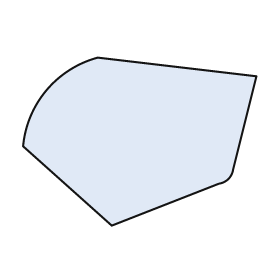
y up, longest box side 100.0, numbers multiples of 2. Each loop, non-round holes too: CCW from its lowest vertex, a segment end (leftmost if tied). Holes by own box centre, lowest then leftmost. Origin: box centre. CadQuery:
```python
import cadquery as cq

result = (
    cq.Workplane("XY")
    .moveTo(-12.0, -36.0)
    .lineTo(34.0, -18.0)
    .threePointArc((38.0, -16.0), (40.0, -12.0))
    .lineTo(50.0, 28.0)
    .lineTo(-18.0, 36.0)
    .threePointArc((-40.0, 22.0), (-50.0, -2.0))
    .close()
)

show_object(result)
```